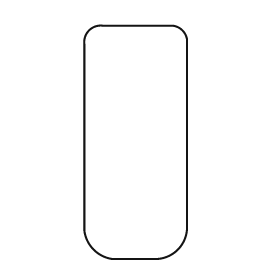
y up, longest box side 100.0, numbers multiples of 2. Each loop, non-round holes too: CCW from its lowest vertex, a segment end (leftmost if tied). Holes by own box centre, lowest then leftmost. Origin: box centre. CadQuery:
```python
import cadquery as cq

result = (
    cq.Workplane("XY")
    .moveTo(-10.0, -50.0)
    .lineTo(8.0, -50.0)
    .threePointArc((18.0, -46.0), (22.0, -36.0))
    .lineTo(22.0, 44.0)
    .threePointArc((20.0, 48.0), (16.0, 50.0))
    .lineTo(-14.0, 50.0)
    .threePointArc((-20.0, 48.0), (-22.0, 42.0))
    .lineTo(-22.0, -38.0)
    .threePointArc((-18.0, -46.0), (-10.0, -50.0))
    .close()
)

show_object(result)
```